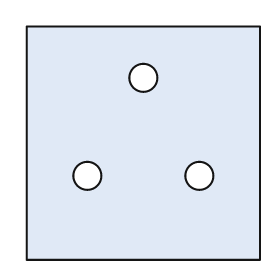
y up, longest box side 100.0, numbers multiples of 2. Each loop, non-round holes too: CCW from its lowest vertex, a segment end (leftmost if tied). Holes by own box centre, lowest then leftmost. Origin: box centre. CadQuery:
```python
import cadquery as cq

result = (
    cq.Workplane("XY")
    .moveTo(-50.0, -50.0)
    .lineTo(50.0, -50.0)
    .lineTo(50.0, 50.0)
    .lineTo(-50.0, 50.0)
    .close()
    .moveTo(-24.0, -14.0)
    .circle(6.0)
    .moveTo(24.0, -14.0)
    .circle(6.0)
    .moveTo(0.0, 28.0)
    .circle(6.0)
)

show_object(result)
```